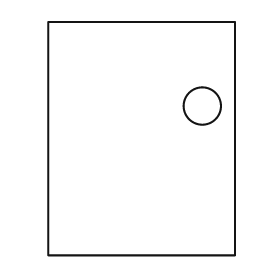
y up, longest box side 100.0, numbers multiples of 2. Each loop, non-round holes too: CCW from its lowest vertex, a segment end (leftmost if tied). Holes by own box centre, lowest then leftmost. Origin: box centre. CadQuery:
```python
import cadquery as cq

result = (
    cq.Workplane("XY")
    .moveTo(-40.0, -50.0)
    .lineTo(40.0, -50.0)
    .lineTo(40.0, 50.0)
    .lineTo(-40.0, 50.0)
    .close()
    .moveTo(26.0, 14.0)
    .circle(8.0)
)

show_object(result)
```